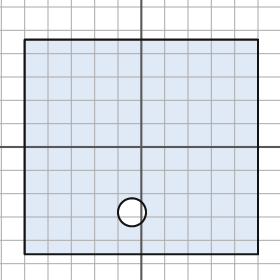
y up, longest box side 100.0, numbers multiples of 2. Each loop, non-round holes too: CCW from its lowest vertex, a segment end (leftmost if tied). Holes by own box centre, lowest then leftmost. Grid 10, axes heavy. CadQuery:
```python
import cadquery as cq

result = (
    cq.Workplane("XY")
    .moveTo(-50.0, -46.0)
    .lineTo(50.0, -46.0)
    .lineTo(50.0, 46.0)
    .lineTo(-50.0, 46.0)
    .close()
    .moveTo(-4.0, -28.0)
    .circle(6.0)
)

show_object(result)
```